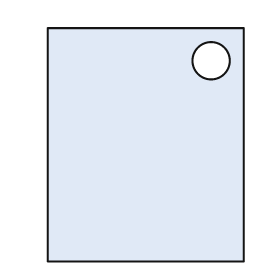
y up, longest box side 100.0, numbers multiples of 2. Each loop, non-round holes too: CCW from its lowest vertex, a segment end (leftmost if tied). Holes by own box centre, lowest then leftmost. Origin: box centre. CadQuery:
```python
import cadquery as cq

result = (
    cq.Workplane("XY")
    .moveTo(-42.0, -50.0)
    .lineTo(42.0, -50.0)
    .lineTo(42.0, 50.0)
    .lineTo(-42.0, 50.0)
    .close()
    .moveTo(28.0, 36.0)
    .circle(8.0)
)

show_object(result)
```